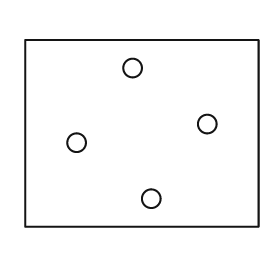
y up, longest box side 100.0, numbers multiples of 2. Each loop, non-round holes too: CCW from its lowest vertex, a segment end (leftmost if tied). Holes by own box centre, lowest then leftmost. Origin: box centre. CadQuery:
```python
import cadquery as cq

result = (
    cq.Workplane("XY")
    .moveTo(-50.0, -40.0)
    .lineTo(50.0, -40.0)
    .lineTo(50.0, 40.0)
    .lineTo(-50.0, 40.0)
    .close()
    .moveTo(4.0, -28.0)
    .circle(4.0)
    .moveTo(-28.0, -4.0)
    .circle(4.0)
    .moveTo(28.0, 4.0)
    .circle(4.0)
    .moveTo(-4.0, 28.0)
    .circle(4.0)
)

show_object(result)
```